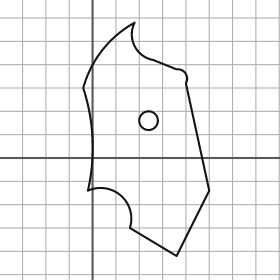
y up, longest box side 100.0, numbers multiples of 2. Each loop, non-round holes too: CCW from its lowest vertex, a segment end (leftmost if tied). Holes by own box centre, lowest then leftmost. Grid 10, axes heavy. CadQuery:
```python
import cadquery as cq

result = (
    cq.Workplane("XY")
    .moveTo(36.0, -42.0)
    .lineTo(50.0, -14.0)
    .lineTo(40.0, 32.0)
    .threePointArc((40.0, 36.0), (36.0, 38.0))
    .lineTo(26.0, 42.0)
    .threePointArc((18.0, 48.0), (18.0, 58.0))
    .threePointArc((4.0, 46.0), (-4.0, 30.0))
    .threePointArc((0.0, 8.0), (-2.0, -14.0))
    .threePointArc((12.0, -16.0), (16.0, -30.0))
    .close()
    .moveTo(24.0, 16.0)
    .circle(4.0)
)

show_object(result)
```